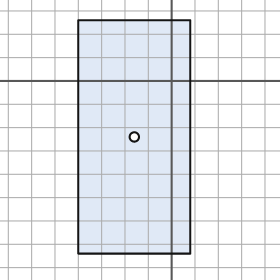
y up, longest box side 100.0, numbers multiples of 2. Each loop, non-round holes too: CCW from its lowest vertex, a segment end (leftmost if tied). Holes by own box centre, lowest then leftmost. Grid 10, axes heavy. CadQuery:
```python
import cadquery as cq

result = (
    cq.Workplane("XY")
    .moveTo(-40.0, -74.0)
    .lineTo(8.0, -74.0)
    .lineTo(8.0, 26.0)
    .lineTo(-40.0, 26.0)
    .close()
    .moveTo(-16.0, -24.0)
    .circle(2.0)
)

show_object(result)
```